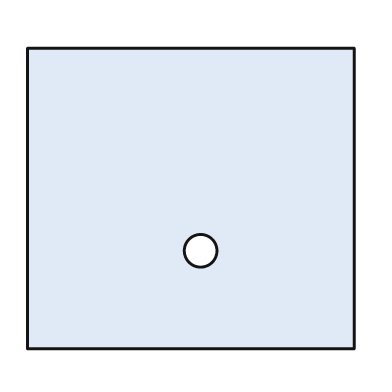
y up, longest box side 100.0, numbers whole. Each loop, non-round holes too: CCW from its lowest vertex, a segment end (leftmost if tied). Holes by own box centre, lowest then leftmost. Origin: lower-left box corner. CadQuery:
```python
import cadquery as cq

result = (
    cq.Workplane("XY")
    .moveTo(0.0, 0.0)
    .lineTo(100.0, 0.0)
    .lineTo(100.0, 92.0)
    .lineTo(0.0, 92.0)
    .close()
    .moveTo(53.0, 30.0)
    .circle(5.0)
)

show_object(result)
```